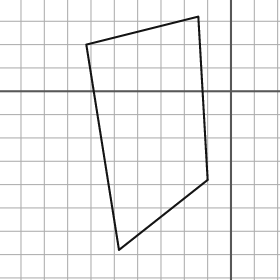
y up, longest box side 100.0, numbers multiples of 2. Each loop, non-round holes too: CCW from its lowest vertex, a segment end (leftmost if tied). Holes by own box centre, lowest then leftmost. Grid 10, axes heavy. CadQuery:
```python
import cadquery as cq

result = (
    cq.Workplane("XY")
    .moveTo(-48.0, -68.0)
    .lineTo(-10.0, -38.0)
    .lineTo(-14.0, 32.0)
    .lineTo(-62.0, 20.0)
    .close()
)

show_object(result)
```